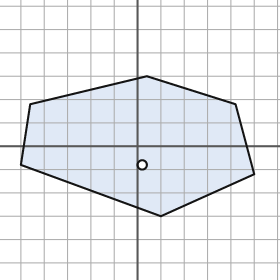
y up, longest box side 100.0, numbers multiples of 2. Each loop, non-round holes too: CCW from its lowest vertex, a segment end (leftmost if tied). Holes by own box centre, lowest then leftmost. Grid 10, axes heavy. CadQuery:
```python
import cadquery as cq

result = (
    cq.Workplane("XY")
    .moveTo(10.0, -30.0)
    .lineTo(50.0, -12.0)
    .lineTo(42.0, 18.0)
    .lineTo(4.0, 30.0)
    .lineTo(-46.0, 18.0)
    .lineTo(-50.0, -8.0)
    .close()
    .moveTo(2.0, -8.0)
    .circle(2.0)
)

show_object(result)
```